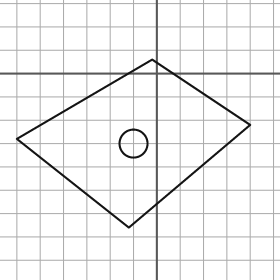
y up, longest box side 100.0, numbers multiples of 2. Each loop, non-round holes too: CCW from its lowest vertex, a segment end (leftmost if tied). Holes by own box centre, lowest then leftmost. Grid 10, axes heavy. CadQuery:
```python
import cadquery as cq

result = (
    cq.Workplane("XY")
    .moveTo(-12.0, -66.0)
    .lineTo(40.0, -22.0)
    .lineTo(-2.0, 6.0)
    .lineTo(-60.0, -28.0)
    .close()
    .moveTo(-10.0, -30.0)
    .circle(6.0)
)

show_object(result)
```